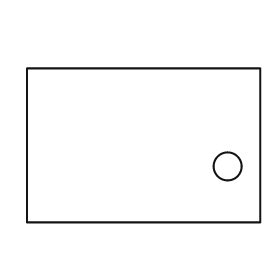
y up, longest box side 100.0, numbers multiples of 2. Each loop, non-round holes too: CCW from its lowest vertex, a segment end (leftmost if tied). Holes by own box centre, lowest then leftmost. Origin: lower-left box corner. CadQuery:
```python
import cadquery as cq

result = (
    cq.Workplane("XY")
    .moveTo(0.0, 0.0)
    .lineTo(100.0, 0.0)
    .lineTo(100.0, 66.0)
    .lineTo(0.0, 66.0)
    .close()
    .moveTo(86.0, 24.0)
    .circle(6.0)
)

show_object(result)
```